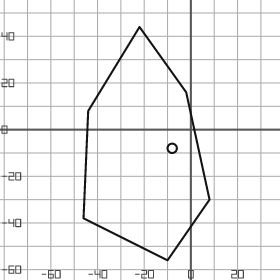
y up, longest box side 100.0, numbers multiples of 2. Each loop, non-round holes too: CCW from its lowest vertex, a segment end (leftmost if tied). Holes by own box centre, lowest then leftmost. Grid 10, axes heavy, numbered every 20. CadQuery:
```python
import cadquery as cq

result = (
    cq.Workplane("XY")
    .moveTo(-10.0, -56.0)
    .lineTo(8.0, -30.0)
    .lineTo(-2.0, 16.0)
    .lineTo(-22.0, 44.0)
    .lineTo(-44.0, 8.0)
    .lineTo(-46.0, -38.0)
    .close()
    .moveTo(-8.0, -8.0)
    .circle(2.0)
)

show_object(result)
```